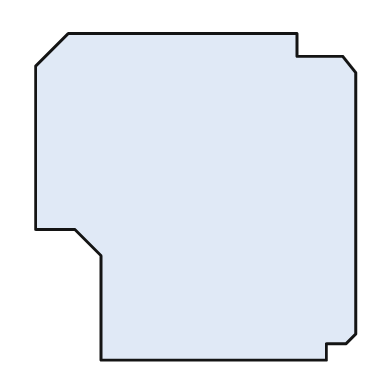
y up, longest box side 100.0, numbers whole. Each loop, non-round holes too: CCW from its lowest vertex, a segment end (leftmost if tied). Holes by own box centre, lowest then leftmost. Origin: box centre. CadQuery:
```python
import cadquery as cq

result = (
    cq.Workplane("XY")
    .moveTo(-29.0, -50.0)
    .lineTo(40.0, -50.0)
    .lineTo(40.0, -45.0)
    .lineTo(46.0, -45.0)
    .lineTo(49.0, -42.0)
    .lineTo(49.0, 38.0)
    .lineTo(45.0, 43.0)
    .lineTo(31.0, 43.0)
    .lineTo(31.0, 50.0)
    .lineTo(-39.0, 50.0)
    .lineTo(-49.0, 40.0)
    .lineTo(-49.0, -10.0)
    .lineTo(-37.0, -10.0)
    .lineTo(-29.0, -18.0)
    .close()
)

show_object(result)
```